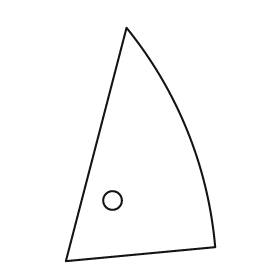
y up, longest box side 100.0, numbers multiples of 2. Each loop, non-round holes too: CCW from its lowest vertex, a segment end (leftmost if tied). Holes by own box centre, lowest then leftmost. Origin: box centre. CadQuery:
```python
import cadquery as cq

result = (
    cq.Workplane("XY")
    .moveTo(-32.0, -50.0)
    .lineTo(32.0, -44.0)
    .threePointArc((20.0, 6.0), (-6.0, 50.0))
    .close()
    .moveTo(-12.0, -24.0)
    .circle(4.0)
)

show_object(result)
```